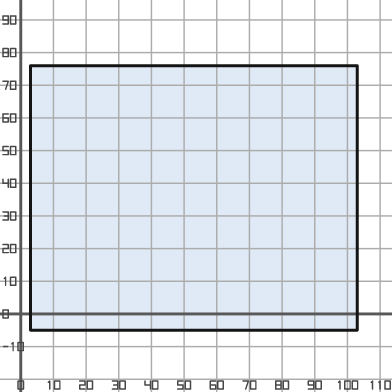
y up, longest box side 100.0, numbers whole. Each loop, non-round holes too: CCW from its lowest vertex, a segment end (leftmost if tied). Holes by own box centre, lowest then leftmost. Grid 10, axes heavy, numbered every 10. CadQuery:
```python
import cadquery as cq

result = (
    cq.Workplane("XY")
    .moveTo(3.0, -5.0)
    .lineTo(103.0, -5.0)
    .lineTo(103.0, 76.0)
    .lineTo(3.0, 76.0)
    .close()
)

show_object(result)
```